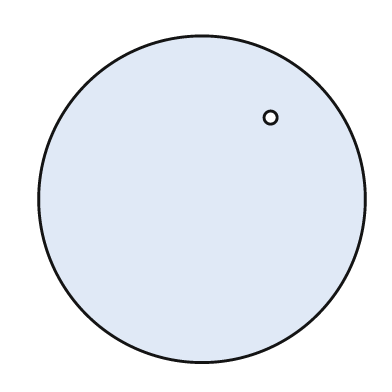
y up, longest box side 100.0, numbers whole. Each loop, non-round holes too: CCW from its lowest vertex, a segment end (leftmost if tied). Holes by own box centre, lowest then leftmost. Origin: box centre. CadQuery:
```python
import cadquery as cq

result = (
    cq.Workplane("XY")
    .moveTo(0.0, 0.0)
    .circle(50.0)
    .moveTo(21.0, 25.0)
    .circle(2.0)
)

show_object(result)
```